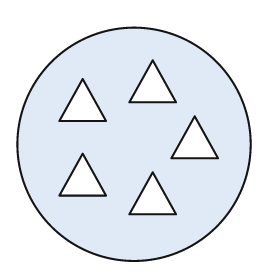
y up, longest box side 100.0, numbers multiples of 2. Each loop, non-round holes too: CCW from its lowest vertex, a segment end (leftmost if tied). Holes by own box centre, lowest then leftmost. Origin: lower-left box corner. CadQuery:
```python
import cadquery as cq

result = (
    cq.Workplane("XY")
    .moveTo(50.0, 50.0)
    .circle(50.0)
    .moveTo(48.0, 20.0)
    .lineTo(68.0, 20.0)
    .lineTo(58.0, 38.0)
    .close()
    .moveTo(18.0, 28.0)
    .lineTo(38.0, 28.0)
    .lineTo(28.0, 46.0)
    .close()
    .moveTo(66.0, 44.0)
    .lineTo(86.0, 44.0)
    .lineTo(76.0, 62.0)
    .close()
    .moveTo(18.0, 60.0)
    .lineTo(38.0, 60.0)
    .lineTo(28.0, 78.0)
    .close()
    .moveTo(48.0, 68.0)
    .lineTo(68.0, 68.0)
    .lineTo(58.0, 86.0)
    .close()
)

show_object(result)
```